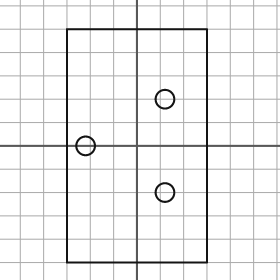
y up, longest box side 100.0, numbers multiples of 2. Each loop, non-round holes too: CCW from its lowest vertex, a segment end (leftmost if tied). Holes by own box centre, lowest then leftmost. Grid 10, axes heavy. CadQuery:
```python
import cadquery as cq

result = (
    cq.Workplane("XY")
    .moveTo(-30.0, -50.0)
    .lineTo(30.0, -50.0)
    .lineTo(30.0, 50.0)
    .lineTo(-30.0, 50.0)
    .close()
    .moveTo(12.0, -20.0)
    .circle(4.0)
    .moveTo(-22.0, 0.0)
    .circle(4.0)
    .moveTo(12.0, 20.0)
    .circle(4.0)
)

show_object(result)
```